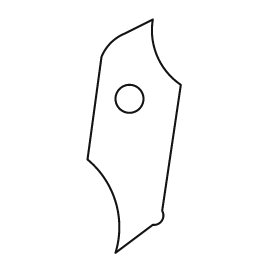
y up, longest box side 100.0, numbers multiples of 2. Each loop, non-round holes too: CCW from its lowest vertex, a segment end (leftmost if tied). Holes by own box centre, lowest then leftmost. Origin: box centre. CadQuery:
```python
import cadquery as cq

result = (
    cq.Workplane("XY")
    .moveTo(-8.0, -50.0)
    .lineTo(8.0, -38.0)
    .threePointArc((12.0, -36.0), (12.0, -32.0))
    .lineTo(20.0, 22.0)
    .threePointArc((10.0, 34.0), (8.0, 50.0))
    .lineTo(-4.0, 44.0)
    .threePointArc((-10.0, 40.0), (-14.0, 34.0))
    .lineTo(-20.0, -10.0)
    .threePointArc((-8.0, -28.0), (-8.0, -50.0))
    .close()
    .moveTo(-2.0, 16.0)
    .circle(6.0)
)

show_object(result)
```